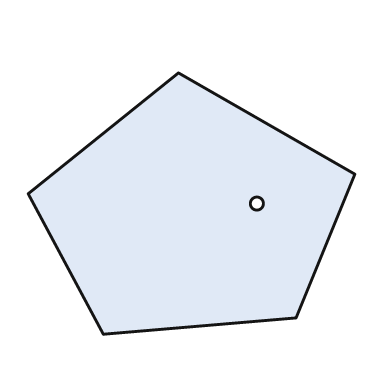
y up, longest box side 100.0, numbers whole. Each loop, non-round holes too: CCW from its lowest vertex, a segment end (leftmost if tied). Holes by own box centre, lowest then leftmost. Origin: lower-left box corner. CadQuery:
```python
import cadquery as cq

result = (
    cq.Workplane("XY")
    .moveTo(23.0, 0.0)
    .lineTo(82.0, 5.0)
    .lineTo(100.0, 49.0)
    .lineTo(46.0, 80.0)
    .lineTo(0.0, 43.0)
    .close()
    .moveTo(70.0, 40.0)
    .circle(2.0)
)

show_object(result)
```